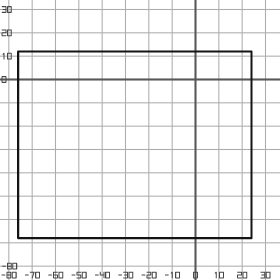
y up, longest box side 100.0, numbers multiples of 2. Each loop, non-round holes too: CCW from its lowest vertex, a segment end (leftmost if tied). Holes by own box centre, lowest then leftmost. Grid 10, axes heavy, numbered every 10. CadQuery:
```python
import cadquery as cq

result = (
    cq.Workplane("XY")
    .moveTo(-76.0, -68.0)
    .lineTo(24.0, -68.0)
    .lineTo(24.0, 12.0)
    .lineTo(-76.0, 12.0)
    .close()
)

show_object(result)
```